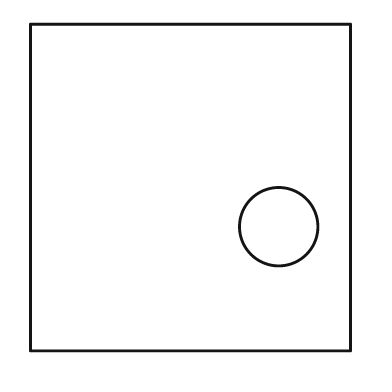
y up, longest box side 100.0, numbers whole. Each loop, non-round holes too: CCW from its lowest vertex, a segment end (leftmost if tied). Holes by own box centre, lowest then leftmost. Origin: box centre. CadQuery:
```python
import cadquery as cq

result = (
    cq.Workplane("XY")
    .moveTo(-49.0, -50.0)
    .lineTo(49.0, -50.0)
    .lineTo(49.0, 50.0)
    .lineTo(-49.0, 50.0)
    .close()
    .moveTo(27.0, -12.0)
    .circle(12.0)
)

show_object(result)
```